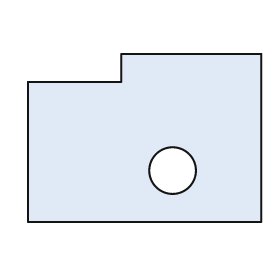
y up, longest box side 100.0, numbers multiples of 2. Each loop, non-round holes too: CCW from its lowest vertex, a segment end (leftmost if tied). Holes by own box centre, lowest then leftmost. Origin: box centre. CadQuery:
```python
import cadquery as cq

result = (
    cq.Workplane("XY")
    .moveTo(-50.0, -36.0)
    .lineTo(50.0, -36.0)
    .lineTo(50.0, 36.0)
    .lineTo(-10.0, 36.0)
    .lineTo(-10.0, 24.0)
    .lineTo(-50.0, 24.0)
    .close()
    .moveTo(12.0, -14.0)
    .circle(10.0)
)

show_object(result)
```